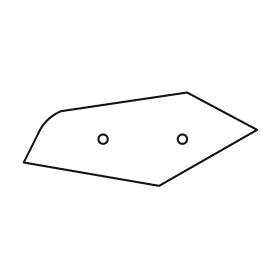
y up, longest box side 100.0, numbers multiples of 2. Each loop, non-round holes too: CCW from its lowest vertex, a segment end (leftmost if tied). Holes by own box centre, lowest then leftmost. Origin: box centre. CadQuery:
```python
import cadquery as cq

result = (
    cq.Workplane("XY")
    .moveTo(8.0, -20.0)
    .lineTo(50.0, 4.0)
    .lineTo(20.0, 20.0)
    .lineTo(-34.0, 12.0)
    .threePointArc((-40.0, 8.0), (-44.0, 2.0))
    .lineTo(-50.0, -10.0)
    .close()
    .moveTo(-16.0, 0.0)
    .circle(2.0)
    .moveTo(18.0, 0.0)
    .circle(2.0)
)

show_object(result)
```